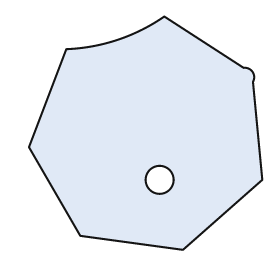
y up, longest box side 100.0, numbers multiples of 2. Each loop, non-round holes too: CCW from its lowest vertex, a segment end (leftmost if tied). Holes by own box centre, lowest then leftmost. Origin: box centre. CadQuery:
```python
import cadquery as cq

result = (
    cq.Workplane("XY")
    .moveTo(16.0, -50.0)
    .lineTo(50.0, -20.0)
    .lineTo(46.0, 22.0)
    .threePointArc((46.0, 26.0), (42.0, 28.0))
    .lineTo(8.0, 50.0)
    .threePointArc((-12.0, 40.0), (-34.0, 36.0))
    .lineTo(-50.0, -6.0)
    .lineTo(-28.0, -44.0)
    .close()
    .moveTo(6.0, -20.0)
    .circle(6.0)
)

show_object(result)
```